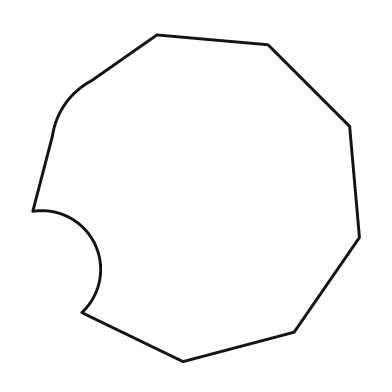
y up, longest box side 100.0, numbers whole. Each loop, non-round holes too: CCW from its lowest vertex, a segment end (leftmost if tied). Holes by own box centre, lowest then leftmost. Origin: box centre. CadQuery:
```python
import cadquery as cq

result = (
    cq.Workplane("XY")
    .moveTo(-4.0, -50.0)
    .lineTo(30.0, -41.0)
    .lineTo(50.0, -12.0)
    .lineTo(47.0, 22.0)
    .lineTo(22.0, 47.0)
    .lineTo(-12.0, 50.0)
    .lineTo(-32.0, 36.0)
    .threePointArc((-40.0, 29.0), (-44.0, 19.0))
    .lineTo(-50.0, -4.0)
    .threePointArc((-31.0, -14.0), (-35.0, -35.0))
    .close()
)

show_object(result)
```